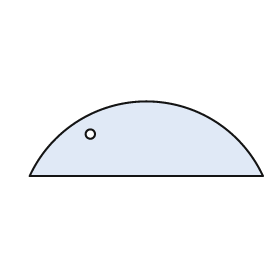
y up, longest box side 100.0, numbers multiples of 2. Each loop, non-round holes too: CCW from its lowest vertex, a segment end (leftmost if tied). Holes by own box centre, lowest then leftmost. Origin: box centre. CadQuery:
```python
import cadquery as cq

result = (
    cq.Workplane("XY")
    .moveTo(-50.0, -16.0)
    .lineTo(50.0, -16.0)
    .threePointArc((0.0, 16.0), (-50.0, -16.0))
    .close()
    .moveTo(-24.0, 2.0)
    .circle(2.0)
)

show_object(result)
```